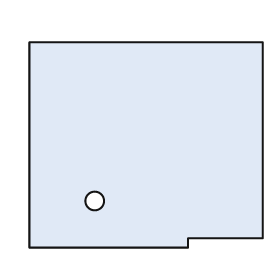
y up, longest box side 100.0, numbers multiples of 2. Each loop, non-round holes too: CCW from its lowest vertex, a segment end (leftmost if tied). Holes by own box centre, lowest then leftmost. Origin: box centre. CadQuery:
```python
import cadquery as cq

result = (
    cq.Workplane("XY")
    .moveTo(-50.0, -44.0)
    .lineTo(18.0, -44.0)
    .lineTo(18.0, -40.0)
    .lineTo(50.0, -40.0)
    .lineTo(50.0, 44.0)
    .lineTo(-50.0, 44.0)
    .close()
    .moveTo(-22.0, -24.0)
    .circle(4.0)
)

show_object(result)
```